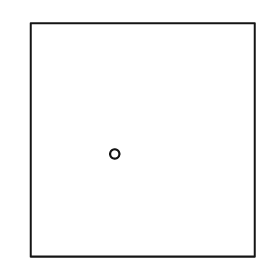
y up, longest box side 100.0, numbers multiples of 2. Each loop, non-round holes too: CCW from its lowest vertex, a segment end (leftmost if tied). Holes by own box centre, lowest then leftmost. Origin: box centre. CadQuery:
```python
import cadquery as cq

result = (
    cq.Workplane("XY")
    .moveTo(-48.0, -50.0)
    .lineTo(48.0, -50.0)
    .lineTo(48.0, 50.0)
    .lineTo(-48.0, 50.0)
    .close()
    .moveTo(-12.0, -6.0)
    .circle(2.0)
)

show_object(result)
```